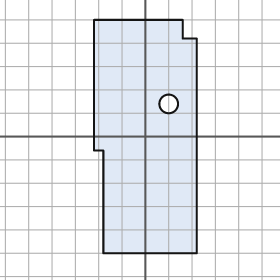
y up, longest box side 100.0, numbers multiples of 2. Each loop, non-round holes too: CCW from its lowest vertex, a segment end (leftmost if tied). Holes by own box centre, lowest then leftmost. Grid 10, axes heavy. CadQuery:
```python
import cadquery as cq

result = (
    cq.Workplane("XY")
    .moveTo(-18.0, -50.0)
    .lineTo(22.0, -50.0)
    .lineTo(22.0, 42.0)
    .lineTo(16.0, 42.0)
    .lineTo(16.0, 50.0)
    .lineTo(-22.0, 50.0)
    .lineTo(-22.0, -6.0)
    .lineTo(-18.0, -6.0)
    .close()
    .moveTo(10.0, 14.0)
    .circle(4.0)
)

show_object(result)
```